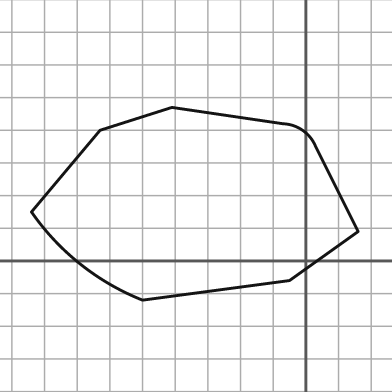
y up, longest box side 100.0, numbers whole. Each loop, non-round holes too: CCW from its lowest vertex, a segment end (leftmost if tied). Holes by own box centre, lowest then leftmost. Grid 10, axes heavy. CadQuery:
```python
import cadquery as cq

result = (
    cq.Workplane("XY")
    .moveTo(-50.0, -12.0)
    .lineTo(-5.0, -6.0)
    .lineTo(16.0, 9.0)
    .lineTo(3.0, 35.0)
    .threePointArc((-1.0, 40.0), (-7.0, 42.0))
    .lineTo(-41.0, 47.0)
    .lineTo(-63.0, 40.0)
    .lineTo(-84.0, 15.0)
    .threePointArc((-69.0, -1.0), (-50.0, -12.0))
    .close()
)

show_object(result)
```